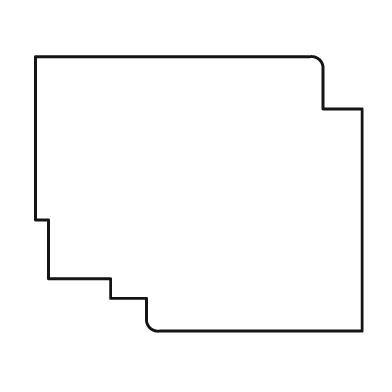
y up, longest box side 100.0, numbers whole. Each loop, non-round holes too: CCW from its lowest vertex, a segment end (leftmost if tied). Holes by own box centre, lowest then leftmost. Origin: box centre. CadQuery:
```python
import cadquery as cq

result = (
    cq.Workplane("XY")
    .moveTo(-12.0, -42.0)
    .lineTo(50.0, -42.0)
    .lineTo(50.0, 26.0)
    .lineTo(38.0, 26.0)
    .lineTo(38.0, 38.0)
    .threePointArc((37.0, 41.0), (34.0, 42.0))
    .lineTo(-50.0, 42.0)
    .lineTo(-50.0, -8.0)
    .lineTo(-46.0, -8.0)
    .lineTo(-46.0, -26.0)
    .lineTo(-27.0, -26.0)
    .lineTo(-27.0, -32.0)
    .lineTo(-16.0, -32.0)
    .lineTo(-16.0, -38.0)
    .threePointArc((-15.0, -41.0), (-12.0, -42.0))
    .close()
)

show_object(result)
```